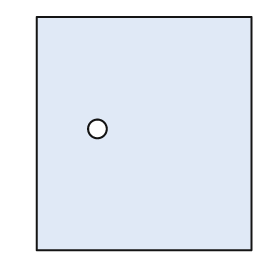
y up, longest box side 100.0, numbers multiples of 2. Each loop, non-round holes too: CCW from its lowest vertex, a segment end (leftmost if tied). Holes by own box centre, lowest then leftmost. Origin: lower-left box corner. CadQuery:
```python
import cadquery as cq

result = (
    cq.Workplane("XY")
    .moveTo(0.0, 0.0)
    .lineTo(92.0, 0.0)
    .lineTo(92.0, 100.0)
    .lineTo(0.0, 100.0)
    .close()
    .moveTo(26.0, 52.0)
    .circle(4.0)
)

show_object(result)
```